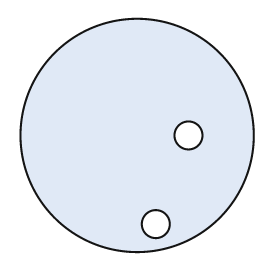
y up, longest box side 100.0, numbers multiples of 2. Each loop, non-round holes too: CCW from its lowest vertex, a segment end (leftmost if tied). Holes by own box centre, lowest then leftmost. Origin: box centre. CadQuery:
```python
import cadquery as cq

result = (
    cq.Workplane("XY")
    .moveTo(0.0, 0.0)
    .circle(50.0)
    .moveTo(8.0, -38.0)
    .circle(6.0)
    .moveTo(22.0, 0.0)
    .circle(6.0)
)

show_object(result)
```